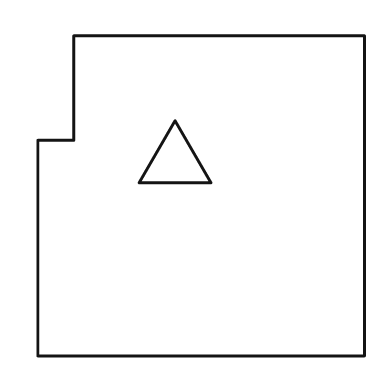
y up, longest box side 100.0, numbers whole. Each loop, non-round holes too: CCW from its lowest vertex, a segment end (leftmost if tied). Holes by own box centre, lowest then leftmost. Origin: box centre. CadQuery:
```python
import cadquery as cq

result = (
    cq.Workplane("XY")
    .moveTo(-50.0, -49.0)
    .lineTo(50.0, -49.0)
    .lineTo(50.0, 49.0)
    .lineTo(-39.0, 49.0)
    .lineTo(-39.0, 17.0)
    .lineTo(-50.0, 17.0)
    .close()
    .moveTo(-19.0, 4.0)
    .lineTo(3.0, 4.0)
    .lineTo(-8.0, 23.0)
    .close()
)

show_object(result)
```